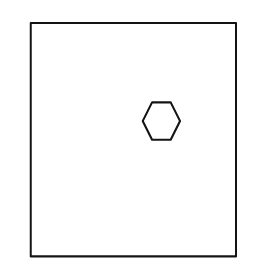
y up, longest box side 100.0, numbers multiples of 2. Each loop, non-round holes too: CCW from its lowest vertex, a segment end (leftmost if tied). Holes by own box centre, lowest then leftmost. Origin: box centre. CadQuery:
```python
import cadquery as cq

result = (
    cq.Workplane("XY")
    .moveTo(-44.0, -50.0)
    .lineTo(44.0, -50.0)
    .lineTo(44.0, 50.0)
    .lineTo(-44.0, 50.0)
    .close()
    .moveTo(8.0, 0.0)
    .lineTo(16.0, 0.0)
    .lineTo(20.0, 8.0)
    .lineTo(16.0, 16.0)
    .lineTo(8.0, 16.0)
    .lineTo(4.0, 8.0)
    .close()
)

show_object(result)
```